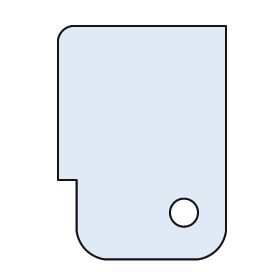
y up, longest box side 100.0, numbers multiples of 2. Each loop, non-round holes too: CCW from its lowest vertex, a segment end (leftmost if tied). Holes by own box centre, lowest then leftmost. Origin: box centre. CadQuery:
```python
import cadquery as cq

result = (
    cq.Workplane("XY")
    .moveTo(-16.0, -50.0)
    .lineTo(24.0, -50.0)
    .threePointArc((32.0, -46.0), (36.0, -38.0))
    .lineTo(36.0, 50.0)
    .lineTo(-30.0, 50.0)
    .threePointArc((-34.0, 48.0), (-36.0, 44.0))
    .lineTo(-36.0, -16.0)
    .lineTo(-28.0, -16.0)
    .lineTo(-28.0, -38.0)
    .threePointArc((-24.0, -46.0), (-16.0, -50.0))
    .close()
    .moveTo(18.0, -30.0)
    .circle(6.0)
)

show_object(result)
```